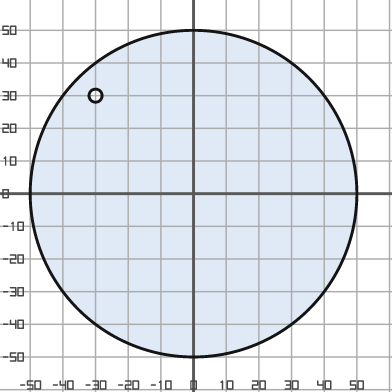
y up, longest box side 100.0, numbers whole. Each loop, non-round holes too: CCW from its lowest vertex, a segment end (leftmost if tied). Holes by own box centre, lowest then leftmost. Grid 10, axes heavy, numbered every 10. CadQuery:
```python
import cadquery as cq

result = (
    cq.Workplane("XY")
    .moveTo(0.0, 0.0)
    .circle(50.0)
    .moveTo(-30.0, 30.0)
    .circle(2.0)
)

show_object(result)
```